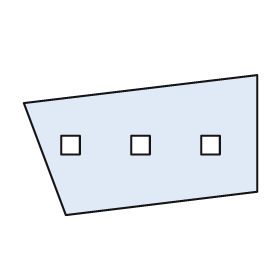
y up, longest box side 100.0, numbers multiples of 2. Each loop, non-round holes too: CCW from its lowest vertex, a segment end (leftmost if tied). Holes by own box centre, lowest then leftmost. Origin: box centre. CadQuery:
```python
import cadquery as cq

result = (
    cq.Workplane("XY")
    .moveTo(-32.0, -30.0)
    .lineTo(50.0, -20.0)
    .lineTo(50.0, 30.0)
    .lineTo(-50.0, 18.0)
    .close()
    .moveTo(-34.0, -4.0)
    .lineTo(-26.0, -4.0)
    .lineTo(-26.0, 4.0)
    .lineTo(-34.0, 4.0)
    .close()
    .moveTo(-4.0, -4.0)
    .lineTo(4.0, -4.0)
    .lineTo(4.0, 4.0)
    .lineTo(-4.0, 4.0)
    .close()
    .moveTo(26.0, -4.0)
    .lineTo(34.0, -4.0)
    .lineTo(34.0, 4.0)
    .lineTo(26.0, 4.0)
    .close()
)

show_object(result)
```